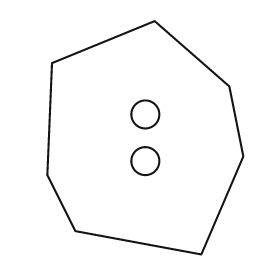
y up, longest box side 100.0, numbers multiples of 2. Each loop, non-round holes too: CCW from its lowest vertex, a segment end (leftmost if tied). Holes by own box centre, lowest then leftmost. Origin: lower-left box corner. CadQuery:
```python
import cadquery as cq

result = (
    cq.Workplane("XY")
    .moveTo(66.0, 0.0)
    .lineTo(84.0, 42.0)
    .lineTo(78.0, 72.0)
    .lineTo(46.0, 100.0)
    .lineTo(2.0, 82.0)
    .lineTo(0.0, 34.0)
    .lineTo(12.0, 10.0)
    .close()
    .moveTo(42.0, 40.0)
    .circle(6.0)
    .moveTo(42.0, 60.0)
    .circle(6.0)
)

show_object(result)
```